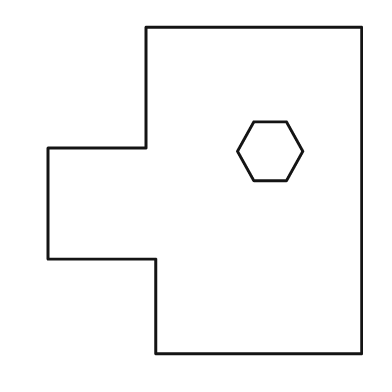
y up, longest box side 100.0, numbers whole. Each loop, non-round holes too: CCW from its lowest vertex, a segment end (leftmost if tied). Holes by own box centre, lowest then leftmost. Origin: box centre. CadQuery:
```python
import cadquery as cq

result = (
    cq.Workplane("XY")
    .moveTo(-15.0, -50.0)
    .lineTo(48.0, -50.0)
    .lineTo(48.0, 50.0)
    .lineTo(-18.0, 50.0)
    .lineTo(-18.0, 13.0)
    .lineTo(-48.0, 13.0)
    .lineTo(-48.0, -21.0)
    .lineTo(-15.0, -21.0)
    .close()
    .moveTo(15.0, 3.0)
    .lineTo(25.0, 3.0)
    .lineTo(30.0, 12.0)
    .lineTo(25.0, 21.0)
    .lineTo(15.0, 21.0)
    .lineTo(10.0, 12.0)
    .close()
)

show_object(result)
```